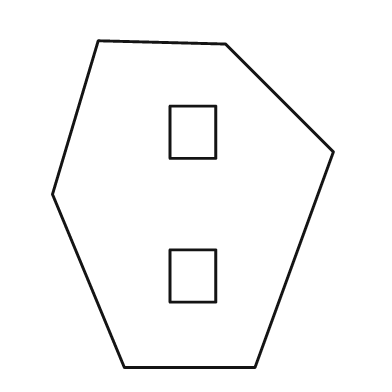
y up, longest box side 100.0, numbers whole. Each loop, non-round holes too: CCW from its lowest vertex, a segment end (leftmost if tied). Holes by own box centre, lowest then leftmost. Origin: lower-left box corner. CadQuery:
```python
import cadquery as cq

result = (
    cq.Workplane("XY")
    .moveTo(22.0, 0.0)
    .lineTo(62.0, 0.0)
    .lineTo(86.0, 66.0)
    .lineTo(53.0, 99.0)
    .lineTo(14.0, 100.0)
    .lineTo(0.0, 53.0)
    .close()
    .moveTo(36.0, 20.0)
    .lineTo(50.0, 20.0)
    .lineTo(50.0, 36.0)
    .lineTo(36.0, 36.0)
    .close()
    .moveTo(36.0, 64.0)
    .lineTo(50.0, 64.0)
    .lineTo(50.0, 80.0)
    .lineTo(36.0, 80.0)
    .close()
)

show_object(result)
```